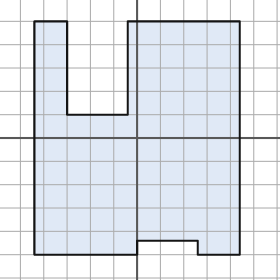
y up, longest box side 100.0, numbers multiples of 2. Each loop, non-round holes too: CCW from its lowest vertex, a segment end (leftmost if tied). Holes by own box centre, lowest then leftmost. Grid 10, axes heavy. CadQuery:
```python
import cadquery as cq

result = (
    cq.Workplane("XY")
    .moveTo(-44.0, -50.0)
    .lineTo(0.0, -50.0)
    .lineTo(0.0, -44.0)
    .lineTo(26.0, -44.0)
    .lineTo(26.0, -50.0)
    .lineTo(44.0, -50.0)
    .lineTo(44.0, 50.0)
    .lineTo(-4.0, 50.0)
    .lineTo(-4.0, 10.0)
    .lineTo(-30.0, 10.0)
    .lineTo(-30.0, 50.0)
    .lineTo(-44.0, 50.0)
    .close()
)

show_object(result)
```